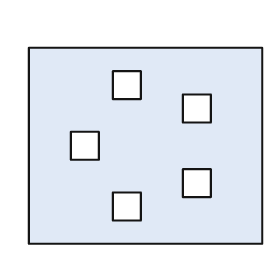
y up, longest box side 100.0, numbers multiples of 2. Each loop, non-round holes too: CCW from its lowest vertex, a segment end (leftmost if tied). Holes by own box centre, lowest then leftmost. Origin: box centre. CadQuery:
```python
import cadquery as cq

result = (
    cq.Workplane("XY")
    .moveTo(-50.0, -42.0)
    .lineTo(50.0, -42.0)
    .lineTo(50.0, 42.0)
    .lineTo(-50.0, 42.0)
    .close()
    .moveTo(-14.0, -32.0)
    .lineTo(-2.0, -32.0)
    .lineTo(-2.0, -20.0)
    .lineTo(-14.0, -20.0)
    .close()
    .moveTo(16.0, -22.0)
    .lineTo(28.0, -22.0)
    .lineTo(28.0, -10.0)
    .lineTo(16.0, -10.0)
    .close()
    .moveTo(-32.0, -6.0)
    .lineTo(-20.0, -6.0)
    .lineTo(-20.0, 6.0)
    .lineTo(-32.0, 6.0)
    .close()
    .moveTo(16.0, 10.0)
    .lineTo(28.0, 10.0)
    .lineTo(28.0, 22.0)
    .lineTo(16.0, 22.0)
    .close()
    .moveTo(-14.0, 20.0)
    .lineTo(-2.0, 20.0)
    .lineTo(-2.0, 32.0)
    .lineTo(-14.0, 32.0)
    .close()
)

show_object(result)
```